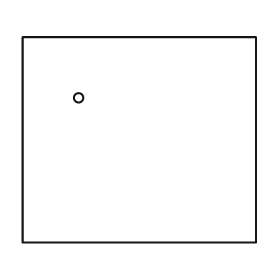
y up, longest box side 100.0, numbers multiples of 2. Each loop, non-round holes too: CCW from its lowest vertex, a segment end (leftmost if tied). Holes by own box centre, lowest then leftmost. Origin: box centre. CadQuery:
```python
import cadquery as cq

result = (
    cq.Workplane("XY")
    .moveTo(-50.0, -44.0)
    .lineTo(50.0, -44.0)
    .lineTo(50.0, 44.0)
    .lineTo(-50.0, 44.0)
    .close()
    .moveTo(-26.0, 18.0)
    .circle(2.0)
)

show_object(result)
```